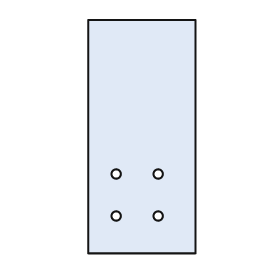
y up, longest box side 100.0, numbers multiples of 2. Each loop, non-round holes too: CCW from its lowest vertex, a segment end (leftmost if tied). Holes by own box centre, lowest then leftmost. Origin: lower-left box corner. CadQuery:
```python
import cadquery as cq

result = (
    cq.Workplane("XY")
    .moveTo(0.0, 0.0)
    .lineTo(46.0, 0.0)
    .lineTo(46.0, 100.0)
    .lineTo(0.0, 100.0)
    .close()
    .moveTo(12.0, 16.0)
    .circle(2.0)
    .moveTo(30.0, 16.0)
    .circle(2.0)
    .moveTo(12.0, 34.0)
    .circle(2.0)
    .moveTo(30.0, 34.0)
    .circle(2.0)
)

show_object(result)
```